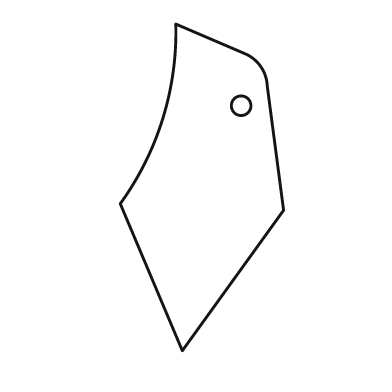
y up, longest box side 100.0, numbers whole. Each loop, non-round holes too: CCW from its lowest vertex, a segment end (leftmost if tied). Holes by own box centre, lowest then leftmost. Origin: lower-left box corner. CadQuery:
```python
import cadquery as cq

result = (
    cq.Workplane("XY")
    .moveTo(19.0, 0.0)
    .lineTo(50.0, 43.0)
    .lineTo(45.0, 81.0)
    .threePointArc((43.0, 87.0), (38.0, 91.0))
    .lineTo(17.0, 100.0)
    .threePointArc((13.0, 71.0), (0.0, 45.0))
    .close()
    .moveTo(37.0, 75.0)
    .circle(3.0)
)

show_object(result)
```